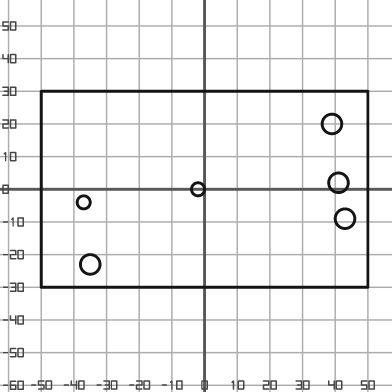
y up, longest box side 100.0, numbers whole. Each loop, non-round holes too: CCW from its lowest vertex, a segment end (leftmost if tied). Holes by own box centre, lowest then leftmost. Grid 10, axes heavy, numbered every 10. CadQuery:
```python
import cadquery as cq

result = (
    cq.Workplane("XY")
    .moveTo(-50.0, -30.0)
    .lineTo(50.0, -30.0)
    .lineTo(50.0, 30.0)
    .lineTo(-50.0, 30.0)
    .close()
    .moveTo(-35.0, -23.0)
    .circle(3.0)
    .moveTo(43.0, -9.0)
    .circle(3.0)
    .moveTo(-37.0, -4.0)
    .circle(2.0)
    .moveTo(-2.0, 0.0)
    .circle(2.0)
    .moveTo(41.0, 2.0)
    .circle(3.0)
    .moveTo(39.0, 20.0)
    .circle(3.0)
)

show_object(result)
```